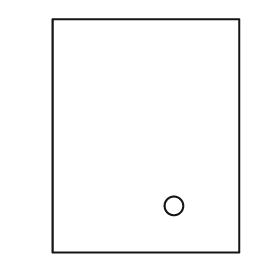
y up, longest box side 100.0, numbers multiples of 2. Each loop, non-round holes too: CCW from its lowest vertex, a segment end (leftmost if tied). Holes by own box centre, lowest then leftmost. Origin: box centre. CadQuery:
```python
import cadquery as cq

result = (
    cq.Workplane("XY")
    .moveTo(-40.0, -50.0)
    .lineTo(40.0, -50.0)
    .lineTo(40.0, 50.0)
    .lineTo(-40.0, 50.0)
    .close()
    .moveTo(12.0, -30.0)
    .circle(4.0)
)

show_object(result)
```